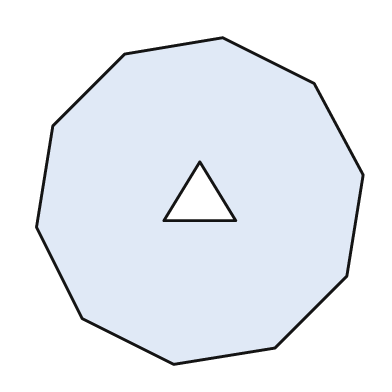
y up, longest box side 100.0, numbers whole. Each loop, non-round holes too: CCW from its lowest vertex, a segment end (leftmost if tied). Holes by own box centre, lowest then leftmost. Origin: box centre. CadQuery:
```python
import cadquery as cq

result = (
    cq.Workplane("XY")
    .moveTo(-8.0, -50.0)
    .lineTo(23.0, -45.0)
    .lineTo(45.0, -23.0)
    .lineTo(50.0, 8.0)
    .lineTo(35.0, 36.0)
    .lineTo(7.0, 50.0)
    .lineTo(-23.0, 45.0)
    .lineTo(-45.0, 23.0)
    .lineTo(-50.0, -8.0)
    .lineTo(-36.0, -36.0)
    .close()
    .moveTo(-11.0, -6.0)
    .lineTo(11.0, -6.0)
    .lineTo(0.0, 12.0)
    .close()
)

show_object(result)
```